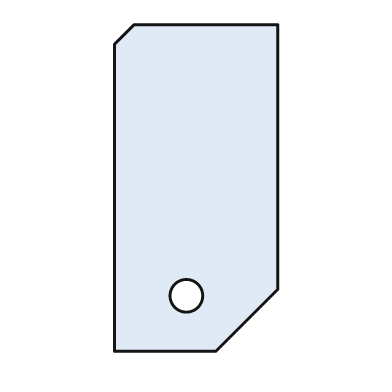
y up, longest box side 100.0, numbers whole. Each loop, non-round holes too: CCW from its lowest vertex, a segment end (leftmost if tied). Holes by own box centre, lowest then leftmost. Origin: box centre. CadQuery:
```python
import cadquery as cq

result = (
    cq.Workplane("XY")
    .moveTo(-25.0, -50.0)
    .lineTo(6.0, -50.0)
    .lineTo(25.0, -31.0)
    .lineTo(25.0, 50.0)
    .lineTo(-19.0, 50.0)
    .lineTo(-25.0, 44.0)
    .close()
    .moveTo(-3.0, -33.0)
    .circle(5.0)
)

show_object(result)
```